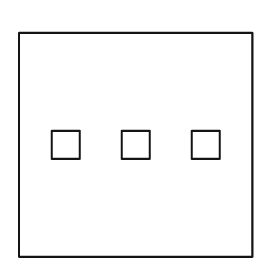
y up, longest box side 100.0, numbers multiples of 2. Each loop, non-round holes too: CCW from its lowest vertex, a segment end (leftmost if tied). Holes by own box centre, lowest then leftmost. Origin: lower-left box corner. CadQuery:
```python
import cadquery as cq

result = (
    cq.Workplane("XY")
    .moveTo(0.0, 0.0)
    .lineTo(100.0, 0.0)
    .lineTo(100.0, 96.0)
    .lineTo(0.0, 96.0)
    .close()
    .moveTo(14.0, 42.0)
    .lineTo(26.0, 42.0)
    .lineTo(26.0, 54.0)
    .lineTo(14.0, 54.0)
    .close()
    .moveTo(44.0, 42.0)
    .lineTo(56.0, 42.0)
    .lineTo(56.0, 54.0)
    .lineTo(44.0, 54.0)
    .close()
    .moveTo(74.0, 42.0)
    .lineTo(86.0, 42.0)
    .lineTo(86.0, 54.0)
    .lineTo(74.0, 54.0)
    .close()
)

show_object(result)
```